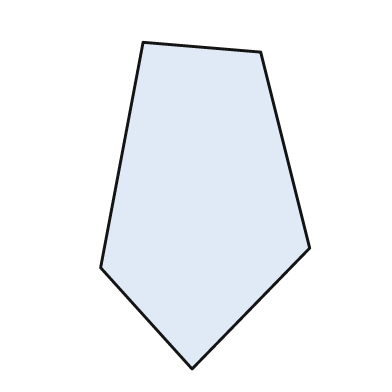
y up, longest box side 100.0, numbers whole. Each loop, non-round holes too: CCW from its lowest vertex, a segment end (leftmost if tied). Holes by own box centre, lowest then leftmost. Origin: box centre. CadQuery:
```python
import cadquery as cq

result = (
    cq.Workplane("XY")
    .moveTo(-4.0, -50.0)
    .lineTo(32.0, -13.0)
    .lineTo(17.0, 47.0)
    .lineTo(-19.0, 50.0)
    .lineTo(-32.0, -19.0)
    .close()
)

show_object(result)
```